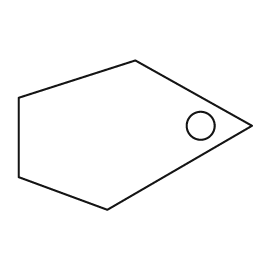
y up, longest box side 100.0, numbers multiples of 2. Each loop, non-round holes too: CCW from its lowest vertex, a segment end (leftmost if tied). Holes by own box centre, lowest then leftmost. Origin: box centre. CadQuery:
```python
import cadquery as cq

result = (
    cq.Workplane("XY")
    .moveTo(-12.0, -32.0)
    .lineTo(50.0, 4.0)
    .lineTo(0.0, 32.0)
    .lineTo(-50.0, 16.0)
    .lineTo(-50.0, -18.0)
    .close()
    .moveTo(28.0, 4.0)
    .circle(6.0)
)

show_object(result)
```